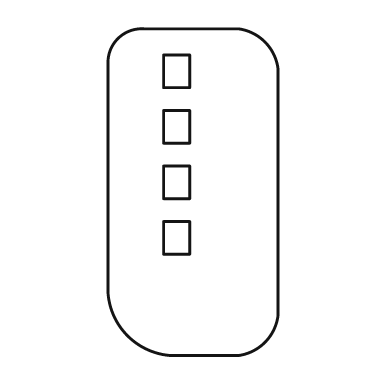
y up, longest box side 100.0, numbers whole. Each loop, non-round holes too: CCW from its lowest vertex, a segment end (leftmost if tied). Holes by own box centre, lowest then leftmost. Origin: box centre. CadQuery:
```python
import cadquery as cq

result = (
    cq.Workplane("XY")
    .moveTo(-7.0, -50.0)
    .lineTo(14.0, -50.0)
    .threePointArc((22.0, -46.0), (26.0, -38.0))
    .lineTo(26.0, 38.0)
    .threePointArc((22.0, 46.0), (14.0, 50.0))
    .lineTo(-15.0, 50.0)
    .threePointArc((-23.0, 47.0), (-26.0, 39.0))
    .lineTo(-26.0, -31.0)
    .threePointArc((-20.0, -44.0), (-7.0, -50.0))
    .close()
    .moveTo(-9.0, -19.0)
    .lineTo(-1.0, -19.0)
    .lineTo(-1.0, -9.0)
    .lineTo(-9.0, -9.0)
    .close()
    .moveTo(-9.0, -2.0)
    .lineTo(-1.0, -2.0)
    .lineTo(-1.0, 8.0)
    .lineTo(-9.0, 8.0)
    .close()
    .moveTo(-9.0, 15.0)
    .lineTo(-1.0, 15.0)
    .lineTo(-1.0, 25.0)
    .lineTo(-9.0, 25.0)
    .close()
    .moveTo(-9.0, 32.0)
    .lineTo(-1.0, 32.0)
    .lineTo(-1.0, 42.0)
    .lineTo(-9.0, 42.0)
    .close()
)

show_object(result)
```